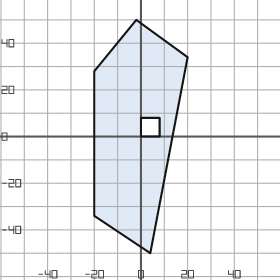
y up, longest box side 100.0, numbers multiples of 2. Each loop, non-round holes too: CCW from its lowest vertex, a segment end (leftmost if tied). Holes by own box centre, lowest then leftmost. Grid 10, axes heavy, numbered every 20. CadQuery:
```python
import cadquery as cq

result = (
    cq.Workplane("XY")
    .moveTo(4.0, -50.0)
    .lineTo(20.0, 34.0)
    .lineTo(-2.0, 50.0)
    .lineTo(-20.0, 28.0)
    .lineTo(-20.0, -34.0)
    .close()
    .moveTo(0.0, 0.0)
    .lineTo(8.0, 0.0)
    .lineTo(8.0, 8.0)
    .lineTo(0.0, 8.0)
    .close()
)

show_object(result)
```